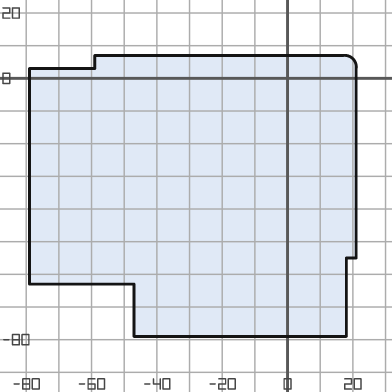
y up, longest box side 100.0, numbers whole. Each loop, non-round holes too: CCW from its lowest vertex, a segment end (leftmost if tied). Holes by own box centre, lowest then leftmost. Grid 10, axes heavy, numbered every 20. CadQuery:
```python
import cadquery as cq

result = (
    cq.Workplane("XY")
    .moveTo(-47.0, -79.0)
    .lineTo(18.0, -79.0)
    .lineTo(18.0, -55.0)
    .lineTo(21.0, -55.0)
    .lineTo(21.0, 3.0)
    .threePointArc((20.0, 6.0), (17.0, 7.0))
    .lineTo(-59.0, 7.0)
    .lineTo(-59.0, 3.0)
    .lineTo(-79.0, 3.0)
    .lineTo(-79.0, -63.0)
    .lineTo(-47.0, -63.0)
    .close()
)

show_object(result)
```